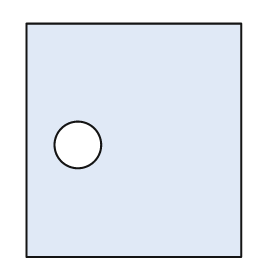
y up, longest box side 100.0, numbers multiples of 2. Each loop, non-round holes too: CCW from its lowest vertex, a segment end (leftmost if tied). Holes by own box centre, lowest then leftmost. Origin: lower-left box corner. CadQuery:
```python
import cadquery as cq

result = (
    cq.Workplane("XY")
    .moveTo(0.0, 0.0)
    .lineTo(92.0, 0.0)
    .lineTo(92.0, 100.0)
    .lineTo(0.0, 100.0)
    .close()
    .moveTo(22.0, 48.0)
    .circle(10.0)
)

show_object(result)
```